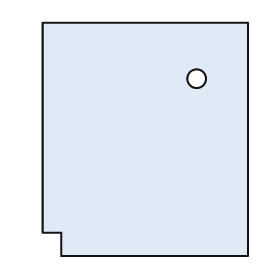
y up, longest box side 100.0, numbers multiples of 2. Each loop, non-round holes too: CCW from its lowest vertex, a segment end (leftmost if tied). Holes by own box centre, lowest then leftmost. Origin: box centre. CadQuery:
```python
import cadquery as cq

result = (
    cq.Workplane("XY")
    .moveTo(-36.0, -50.0)
    .lineTo(44.0, -50.0)
    .lineTo(44.0, 50.0)
    .lineTo(-44.0, 50.0)
    .lineTo(-44.0, -40.0)
    .lineTo(-36.0, -40.0)
    .close()
    .moveTo(22.0, 26.0)
    .circle(4.0)
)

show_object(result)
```